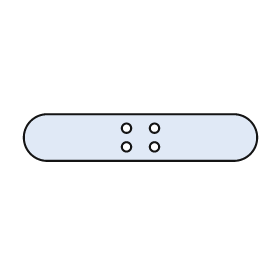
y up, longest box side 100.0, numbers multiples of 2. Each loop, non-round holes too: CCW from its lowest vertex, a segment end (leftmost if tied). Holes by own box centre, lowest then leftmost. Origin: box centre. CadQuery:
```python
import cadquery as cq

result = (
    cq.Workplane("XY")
    .moveTo(-40.0, -10.0)
    .lineTo(40.0, -10.0)
    .threePointArc((50.0, 0.0), (40.0, 10.0))
    .lineTo(-40.0, 10.0)
    .threePointArc((-50.0, 0.0), (-40.0, -10.0))
    .close()
    .moveTo(-6.0, -4.0)
    .circle(2.0)
    .moveTo(6.0, -4.0)
    .circle(2.0)
    .moveTo(-6.0, 4.0)
    .circle(2.0)
    .moveTo(6.0, 4.0)
    .circle(2.0)
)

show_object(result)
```